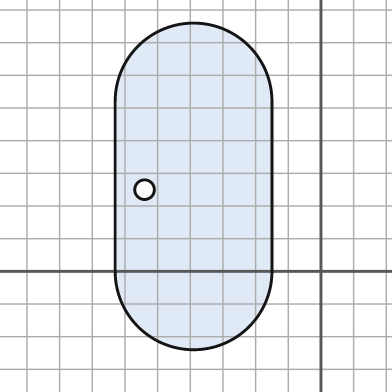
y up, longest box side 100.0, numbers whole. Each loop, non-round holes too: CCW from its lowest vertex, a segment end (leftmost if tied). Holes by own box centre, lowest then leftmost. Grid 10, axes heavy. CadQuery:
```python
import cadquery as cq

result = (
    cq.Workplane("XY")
    .moveTo(-63.0, 0.0)
    .threePointArc((-39.0, -24.0), (-15.0, 0.0))
    .lineTo(-15.0, 52.0)
    .threePointArc((-39.0, 76.0), (-63.0, 52.0))
    .close()
    .moveTo(-54.0, 25.0)
    .circle(3.0)
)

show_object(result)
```